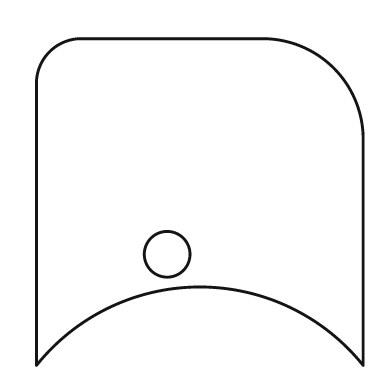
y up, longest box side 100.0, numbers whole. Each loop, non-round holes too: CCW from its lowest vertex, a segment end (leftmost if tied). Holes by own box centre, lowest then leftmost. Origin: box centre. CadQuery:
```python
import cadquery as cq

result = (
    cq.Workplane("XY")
    .moveTo(-50.0, -50.0)
    .threePointArc((0.0, -26.0), (50.0, -50.0))
    .lineTo(50.0, 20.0)
    .threePointArc((41.0, 41.0), (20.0, 50.0))
    .lineTo(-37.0, 50.0)
    .threePointArc((-46.0, 46.0), (-50.0, 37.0))
    .close()
    .moveTo(-10.0, -16.0)
    .circle(7.0)
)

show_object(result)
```